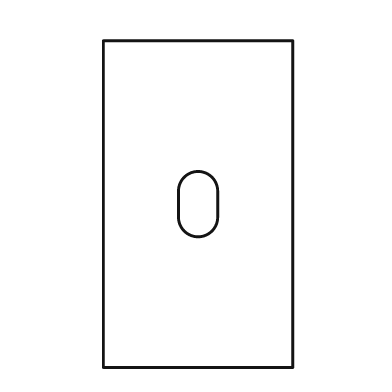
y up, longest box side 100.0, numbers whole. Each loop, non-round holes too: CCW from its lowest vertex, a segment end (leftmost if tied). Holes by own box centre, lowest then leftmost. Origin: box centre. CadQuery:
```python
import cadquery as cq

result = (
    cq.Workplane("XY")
    .moveTo(-29.0, -50.0)
    .lineTo(29.0, -50.0)
    .lineTo(29.0, 50.0)
    .lineTo(-29.0, 50.0)
    .close()
    .moveTo(-6.0, -4.0)
    .threePointArc((0.0, -10.0), (6.0, -4.0))
    .lineTo(6.0, 4.0)
    .threePointArc((0.0, 10.0), (-6.0, 4.0))
    .close()
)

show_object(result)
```